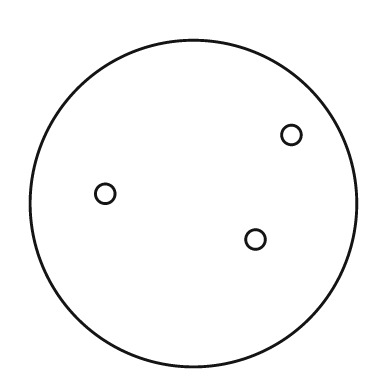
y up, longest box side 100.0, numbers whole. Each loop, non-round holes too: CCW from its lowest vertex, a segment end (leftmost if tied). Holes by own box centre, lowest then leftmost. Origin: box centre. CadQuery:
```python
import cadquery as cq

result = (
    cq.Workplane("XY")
    .moveTo(0.0, 0.0)
    .circle(50.0)
    .moveTo(19.0, -11.0)
    .circle(3.0)
    .moveTo(-27.0, 3.0)
    .circle(3.0)
    .moveTo(30.0, 21.0)
    .circle(3.0)
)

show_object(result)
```